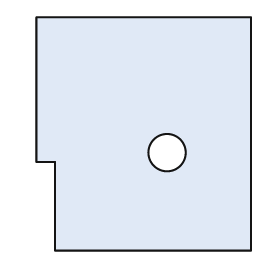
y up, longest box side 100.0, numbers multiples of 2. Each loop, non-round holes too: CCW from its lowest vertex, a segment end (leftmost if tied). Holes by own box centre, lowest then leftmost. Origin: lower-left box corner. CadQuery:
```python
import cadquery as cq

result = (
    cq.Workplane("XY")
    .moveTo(8.0, 0.0)
    .lineTo(92.0, 0.0)
    .lineTo(92.0, 100.0)
    .lineTo(0.0, 100.0)
    .lineTo(0.0, 38.0)
    .lineTo(8.0, 38.0)
    .close()
    .moveTo(56.0, 42.0)
    .circle(8.0)
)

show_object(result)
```